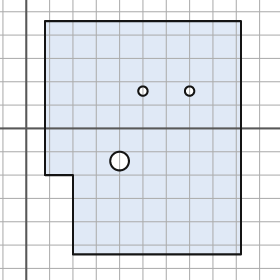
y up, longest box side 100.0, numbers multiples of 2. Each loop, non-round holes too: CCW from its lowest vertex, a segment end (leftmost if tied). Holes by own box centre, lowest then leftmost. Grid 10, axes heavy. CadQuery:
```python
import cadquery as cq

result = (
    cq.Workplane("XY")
    .moveTo(20.0, -54.0)
    .lineTo(92.0, -54.0)
    .lineTo(92.0, 46.0)
    .lineTo(8.0, 46.0)
    .lineTo(8.0, -20.0)
    .lineTo(20.0, -20.0)
    .close()
    .moveTo(40.0, -14.0)
    .circle(4.0)
    .moveTo(50.0, 16.0)
    .circle(2.0)
    .moveTo(70.0, 16.0)
    .circle(2.0)
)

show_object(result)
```